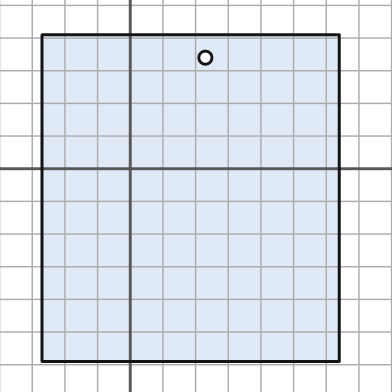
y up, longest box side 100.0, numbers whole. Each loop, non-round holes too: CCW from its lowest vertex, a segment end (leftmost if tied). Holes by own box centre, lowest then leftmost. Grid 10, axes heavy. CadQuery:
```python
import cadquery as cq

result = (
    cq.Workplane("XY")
    .moveTo(-27.0, -59.0)
    .lineTo(64.0, -59.0)
    .lineTo(64.0, 41.0)
    .lineTo(-27.0, 41.0)
    .close()
    .moveTo(23.0, 34.0)
    .circle(2.0)
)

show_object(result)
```